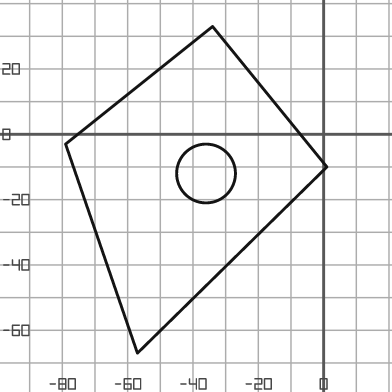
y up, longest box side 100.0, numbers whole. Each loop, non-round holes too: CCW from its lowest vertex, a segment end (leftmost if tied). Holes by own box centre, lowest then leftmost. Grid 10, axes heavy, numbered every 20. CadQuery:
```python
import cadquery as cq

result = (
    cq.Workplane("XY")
    .moveTo(-57.0, -67.0)
    .lineTo(1.0, -10.0)
    .lineTo(-34.0, 33.0)
    .lineTo(-79.0, -3.0)
    .close()
    .moveTo(-36.0, -12.0)
    .circle(9.0)
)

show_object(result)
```